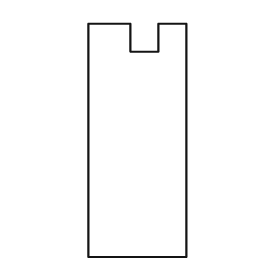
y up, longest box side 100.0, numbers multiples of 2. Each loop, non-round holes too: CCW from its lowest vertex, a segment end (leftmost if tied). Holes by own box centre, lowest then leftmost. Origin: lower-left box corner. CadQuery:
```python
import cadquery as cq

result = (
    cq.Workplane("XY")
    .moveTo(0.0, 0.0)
    .lineTo(42.0, 0.0)
    .lineTo(42.0, 100.0)
    .lineTo(30.0, 100.0)
    .lineTo(30.0, 88.0)
    .lineTo(18.0, 88.0)
    .lineTo(18.0, 100.0)
    .lineTo(0.0, 100.0)
    .close()
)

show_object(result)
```